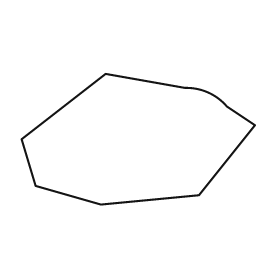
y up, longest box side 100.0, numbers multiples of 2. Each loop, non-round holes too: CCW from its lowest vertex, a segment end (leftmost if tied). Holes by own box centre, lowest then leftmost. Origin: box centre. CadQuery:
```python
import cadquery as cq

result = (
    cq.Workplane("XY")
    .moveTo(-16.0, -28.0)
    .lineTo(26.0, -24.0)
    .lineTo(50.0, 6.0)
    .lineTo(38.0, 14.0)
    .threePointArc((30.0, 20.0), (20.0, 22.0))
    .lineTo(-14.0, 28.0)
    .lineTo(-50.0, 0.0)
    .lineTo(-44.0, -20.0)
    .close()
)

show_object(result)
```